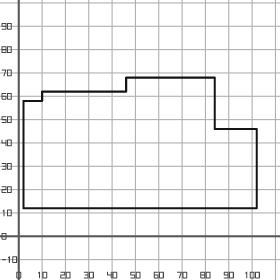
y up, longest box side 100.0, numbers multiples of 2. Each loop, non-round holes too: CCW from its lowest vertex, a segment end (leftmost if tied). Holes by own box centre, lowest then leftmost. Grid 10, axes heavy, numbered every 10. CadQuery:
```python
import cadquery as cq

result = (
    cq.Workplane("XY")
    .moveTo(2.0, 12.0)
    .lineTo(102.0, 12.0)
    .lineTo(102.0, 46.0)
    .lineTo(84.0, 46.0)
    .lineTo(84.0, 68.0)
    .lineTo(46.0, 68.0)
    .lineTo(46.0, 62.0)
    .lineTo(10.0, 62.0)
    .lineTo(10.0, 58.0)
    .lineTo(2.0, 58.0)
    .close()
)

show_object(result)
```